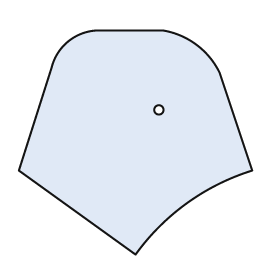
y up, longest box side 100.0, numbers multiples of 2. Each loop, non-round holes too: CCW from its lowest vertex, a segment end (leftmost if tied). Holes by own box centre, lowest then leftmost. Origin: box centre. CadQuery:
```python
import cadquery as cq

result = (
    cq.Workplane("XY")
    .moveTo(0.0, -48.0)
    .threePointArc((22.0, -26.0), (50.0, -12.0))
    .lineTo(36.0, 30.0)
    .threePointArc((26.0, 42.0), (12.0, 48.0))
    .lineTo(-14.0, 48.0)
    .threePointArc((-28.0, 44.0), (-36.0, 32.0))
    .lineTo(-50.0, -12.0)
    .close()
    .moveTo(10.0, 14.0)
    .circle(2.0)
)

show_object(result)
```